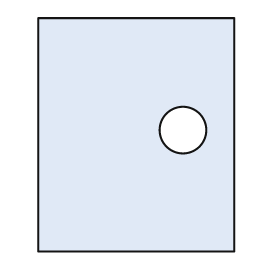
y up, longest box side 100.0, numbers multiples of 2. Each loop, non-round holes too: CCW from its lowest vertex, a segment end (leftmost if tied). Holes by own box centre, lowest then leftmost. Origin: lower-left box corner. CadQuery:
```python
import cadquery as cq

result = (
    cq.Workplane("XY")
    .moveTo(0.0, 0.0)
    .lineTo(84.0, 0.0)
    .lineTo(84.0, 100.0)
    .lineTo(0.0, 100.0)
    .close()
    .moveTo(62.0, 52.0)
    .circle(10.0)
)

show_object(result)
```